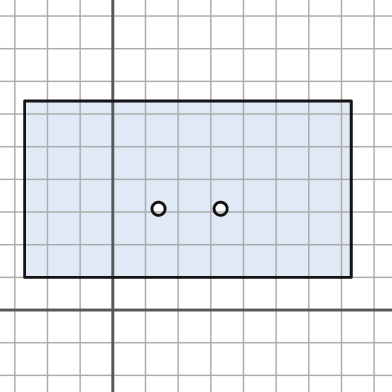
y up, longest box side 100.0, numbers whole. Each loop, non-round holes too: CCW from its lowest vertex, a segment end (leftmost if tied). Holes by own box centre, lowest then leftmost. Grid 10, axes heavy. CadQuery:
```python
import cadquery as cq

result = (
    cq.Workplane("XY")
    .moveTo(-27.0, 10.0)
    .lineTo(73.0, 10.0)
    .lineTo(73.0, 64.0)
    .lineTo(-27.0, 64.0)
    .close()
    .moveTo(14.0, 31.0)
    .circle(2.0)
    .moveTo(33.0, 31.0)
    .circle(2.0)
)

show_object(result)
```